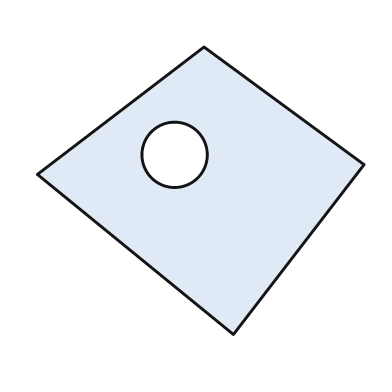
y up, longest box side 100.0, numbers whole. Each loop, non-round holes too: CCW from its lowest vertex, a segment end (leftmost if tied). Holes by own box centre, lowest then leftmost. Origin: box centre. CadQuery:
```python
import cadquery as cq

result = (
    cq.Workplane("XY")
    .moveTo(10.0, -44.0)
    .lineTo(50.0, 8.0)
    .lineTo(1.0, 44.0)
    .lineTo(-50.0, 5.0)
    .close()
    .moveTo(-8.0, 11.0)
    .circle(10.0)
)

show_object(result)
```